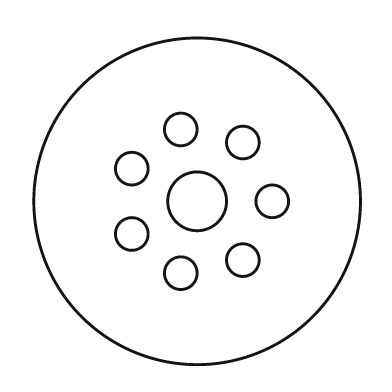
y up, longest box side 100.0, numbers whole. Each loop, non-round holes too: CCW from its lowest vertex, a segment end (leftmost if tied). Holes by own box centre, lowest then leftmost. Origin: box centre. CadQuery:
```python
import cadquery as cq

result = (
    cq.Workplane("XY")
    .moveTo(0.0, 0.0)
    .circle(50.0)
    .moveTo(-5.0, -22.0)
    .circle(5.0)
    .moveTo(14.0, -18.0)
    .circle(5.0)
    .moveTo(-20.0, -10.0)
    .circle(5.0)
    .moveTo(0.0, 0.0)
    .circle(9.0)
    .moveTo(23.0, 0.0)
    .circle(5.0)
    .moveTo(-20.0, 10.0)
    .circle(5.0)
    .moveTo(14.0, 18.0)
    .circle(5.0)
    .moveTo(-5.0, 22.0)
    .circle(5.0)
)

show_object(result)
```